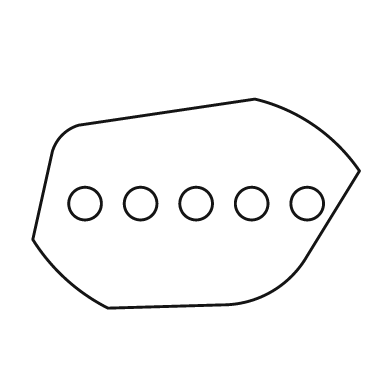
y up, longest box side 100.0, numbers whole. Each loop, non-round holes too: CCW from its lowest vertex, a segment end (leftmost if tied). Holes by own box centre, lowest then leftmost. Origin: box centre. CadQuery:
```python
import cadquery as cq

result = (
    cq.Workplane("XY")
    .moveTo(-27.0, -32.0)
    .lineTo(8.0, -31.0)
    .threePointArc((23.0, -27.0), (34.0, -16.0))
    .lineTo(50.0, 10.0)
    .threePointArc((36.0, 24.0), (18.0, 32.0))
    .lineTo(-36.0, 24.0)
    .threePointArc((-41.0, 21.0), (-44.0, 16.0))
    .lineTo(-50.0, -11.0)
    .threePointArc((-40.0, -23.0), (-27.0, -32.0))
    .close()
    .moveTo(-34.0, 0.0)
    .circle(5.0)
    .moveTo(-17.0, 0.0)
    .circle(5.0)
    .moveTo(0.0, 0.0)
    .circle(5.0)
    .moveTo(17.0, 0.0)
    .circle(5.0)
    .moveTo(34.0, 0.0)
    .circle(5.0)
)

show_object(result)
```